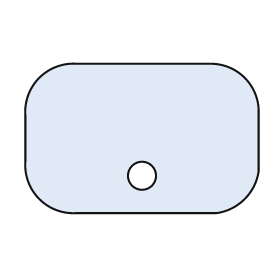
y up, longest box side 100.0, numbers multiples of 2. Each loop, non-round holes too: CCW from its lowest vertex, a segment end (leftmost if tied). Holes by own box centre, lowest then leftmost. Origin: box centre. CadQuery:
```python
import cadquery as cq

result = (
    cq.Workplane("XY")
    .moveTo(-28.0, -32.0)
    .lineTo(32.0, -32.0)
    .threePointArc((44.0, -26.0), (50.0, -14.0))
    .lineTo(50.0, 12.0)
    .threePointArc((44.0, 26.0), (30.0, 32.0))
    .lineTo(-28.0, 32.0)
    .threePointArc((-44.0, 26.0), (-50.0, 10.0))
    .lineTo(-50.0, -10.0)
    .threePointArc((-44.0, -26.0), (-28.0, -32.0))
    .close()
    .moveTo(0.0, -16.0)
    .circle(6.0)
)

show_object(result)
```